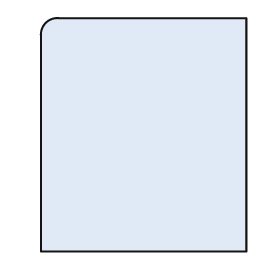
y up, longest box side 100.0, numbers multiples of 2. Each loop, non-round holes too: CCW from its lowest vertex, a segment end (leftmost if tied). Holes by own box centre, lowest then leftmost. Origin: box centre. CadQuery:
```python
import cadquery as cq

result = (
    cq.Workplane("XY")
    .moveTo(-44.0, -50.0)
    .lineTo(44.0, -50.0)
    .lineTo(44.0, 50.0)
    .lineTo(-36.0, 50.0)
    .threePointArc((-42.0, 48.0), (-44.0, 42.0))
    .close()
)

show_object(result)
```